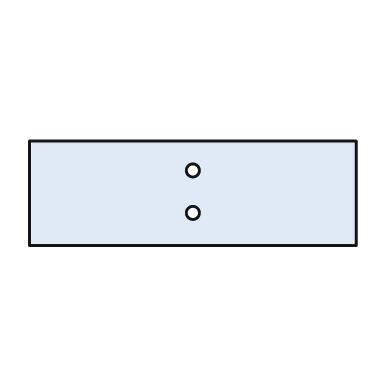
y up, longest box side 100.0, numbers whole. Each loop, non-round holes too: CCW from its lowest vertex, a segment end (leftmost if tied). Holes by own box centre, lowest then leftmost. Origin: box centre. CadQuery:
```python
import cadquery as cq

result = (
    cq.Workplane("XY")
    .moveTo(-50.0, -16.0)
    .lineTo(50.0, -16.0)
    .lineTo(50.0, 16.0)
    .lineTo(-50.0, 16.0)
    .close()
    .moveTo(0.0, -6.0)
    .circle(2.0)
    .moveTo(0.0, 7.0)
    .circle(2.0)
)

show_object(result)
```